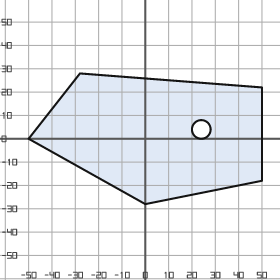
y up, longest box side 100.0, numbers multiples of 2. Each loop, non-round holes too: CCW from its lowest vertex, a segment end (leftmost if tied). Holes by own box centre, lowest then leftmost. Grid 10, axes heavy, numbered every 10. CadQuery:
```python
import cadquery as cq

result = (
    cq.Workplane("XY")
    .moveTo(0.0, -28.0)
    .lineTo(50.0, -18.0)
    .lineTo(50.0, 22.0)
    .lineTo(-28.0, 28.0)
    .lineTo(-50.0, 0.0)
    .close()
    .moveTo(24.0, 4.0)
    .circle(4.0)
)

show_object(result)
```